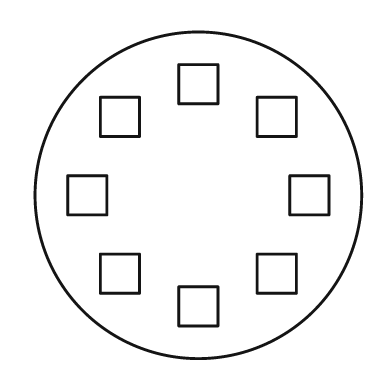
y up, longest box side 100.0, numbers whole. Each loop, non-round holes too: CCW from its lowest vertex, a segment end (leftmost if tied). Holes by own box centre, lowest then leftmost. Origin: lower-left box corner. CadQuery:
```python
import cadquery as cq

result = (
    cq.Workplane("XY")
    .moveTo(50.0, 50.0)
    .circle(50.0)
    .moveTo(44.0, 10.0)
    .lineTo(56.0, 10.0)
    .lineTo(56.0, 22.0)
    .lineTo(44.0, 22.0)
    .close()
    .moveTo(20.0, 20.0)
    .lineTo(32.0, 20.0)
    .lineTo(32.0, 32.0)
    .lineTo(20.0, 32.0)
    .close()
    .moveTo(68.0, 20.0)
    .lineTo(80.0, 20.0)
    .lineTo(80.0, 32.0)
    .lineTo(68.0, 32.0)
    .close()
    .moveTo(10.0, 44.0)
    .lineTo(22.0, 44.0)
    .lineTo(22.0, 56.0)
    .lineTo(10.0, 56.0)
    .close()
    .moveTo(78.0, 44.0)
    .lineTo(90.0, 44.0)
    .lineTo(90.0, 56.0)
    .lineTo(78.0, 56.0)
    .close()
    .moveTo(20.0, 68.0)
    .lineTo(32.0, 68.0)
    .lineTo(32.0, 80.0)
    .lineTo(20.0, 80.0)
    .close()
    .moveTo(68.0, 68.0)
    .lineTo(80.0, 68.0)
    .lineTo(80.0, 80.0)
    .lineTo(68.0, 80.0)
    .close()
    .moveTo(44.0, 78.0)
    .lineTo(56.0, 78.0)
    .lineTo(56.0, 90.0)
    .lineTo(44.0, 90.0)
    .close()
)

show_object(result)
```